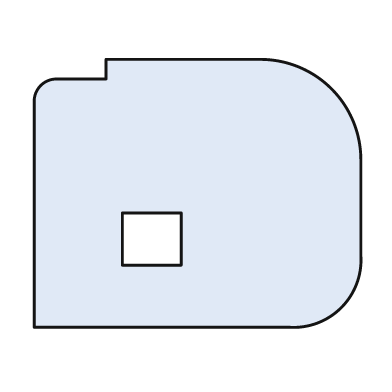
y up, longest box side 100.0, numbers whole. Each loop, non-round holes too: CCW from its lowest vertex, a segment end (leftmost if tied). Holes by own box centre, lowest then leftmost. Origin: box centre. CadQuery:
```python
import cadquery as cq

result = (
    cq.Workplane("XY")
    .moveTo(-50.0, -41.0)
    .lineTo(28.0, -41.0)
    .threePointArc((44.0, -35.0), (50.0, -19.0))
    .lineTo(50.0, 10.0)
    .threePointArc((41.0, 32.0), (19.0, 41.0))
    .lineTo(-28.0, 41.0)
    .lineTo(-28.0, 35.0)
    .lineTo(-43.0, 35.0)
    .threePointArc((-48.0, 33.0), (-50.0, 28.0))
    .close()
    .moveTo(-23.0, -22.0)
    .lineTo(-5.0, -22.0)
    .lineTo(-5.0, -6.0)
    .lineTo(-23.0, -6.0)
    .close()
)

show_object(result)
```